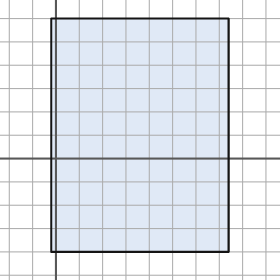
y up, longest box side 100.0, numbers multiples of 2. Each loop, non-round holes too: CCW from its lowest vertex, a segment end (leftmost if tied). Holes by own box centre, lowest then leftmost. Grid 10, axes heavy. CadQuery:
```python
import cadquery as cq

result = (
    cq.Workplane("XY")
    .moveTo(-2.0, -40.0)
    .lineTo(74.0, -40.0)
    .lineTo(74.0, 60.0)
    .lineTo(-2.0, 60.0)
    .close()
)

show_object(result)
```